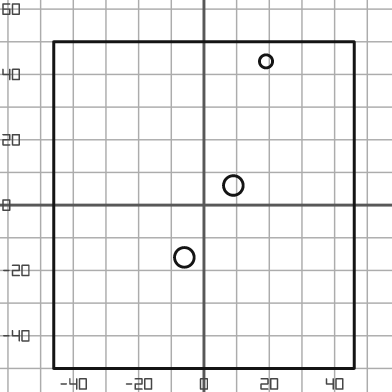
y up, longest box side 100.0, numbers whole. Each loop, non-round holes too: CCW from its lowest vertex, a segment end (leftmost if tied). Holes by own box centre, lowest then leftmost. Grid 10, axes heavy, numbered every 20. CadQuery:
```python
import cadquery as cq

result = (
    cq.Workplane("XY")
    .moveTo(-46.0, -50.0)
    .lineTo(46.0, -50.0)
    .lineTo(46.0, 50.0)
    .lineTo(-46.0, 50.0)
    .close()
    .moveTo(-6.0, -16.0)
    .circle(3.0)
    .moveTo(9.0, 6.0)
    .circle(3.0)
    .moveTo(19.0, 44.0)
    .circle(2.0)
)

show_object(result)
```